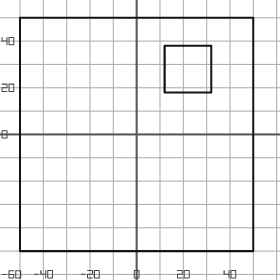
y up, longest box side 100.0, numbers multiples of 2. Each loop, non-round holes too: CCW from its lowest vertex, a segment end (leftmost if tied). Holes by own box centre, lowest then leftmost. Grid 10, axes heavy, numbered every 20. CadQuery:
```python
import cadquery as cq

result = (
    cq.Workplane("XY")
    .moveTo(-50.0, -50.0)
    .lineTo(50.0, -50.0)
    .lineTo(50.0, 50.0)
    .lineTo(-50.0, 50.0)
    .close()
    .moveTo(12.0, 18.0)
    .lineTo(32.0, 18.0)
    .lineTo(32.0, 38.0)
    .lineTo(12.0, 38.0)
    .close()
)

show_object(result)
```